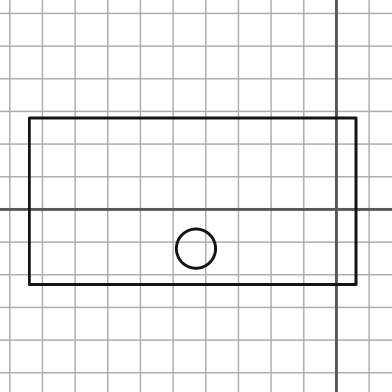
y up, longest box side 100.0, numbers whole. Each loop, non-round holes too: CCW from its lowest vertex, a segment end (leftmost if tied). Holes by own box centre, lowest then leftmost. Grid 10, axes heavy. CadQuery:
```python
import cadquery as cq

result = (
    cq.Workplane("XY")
    .moveTo(-94.0, -23.0)
    .lineTo(6.0, -23.0)
    .lineTo(6.0, 28.0)
    .lineTo(-94.0, 28.0)
    .close()
    .moveTo(-43.0, -12.0)
    .circle(6.0)
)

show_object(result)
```